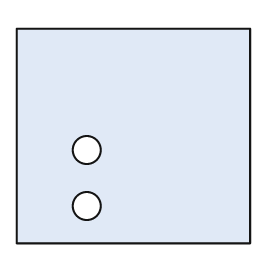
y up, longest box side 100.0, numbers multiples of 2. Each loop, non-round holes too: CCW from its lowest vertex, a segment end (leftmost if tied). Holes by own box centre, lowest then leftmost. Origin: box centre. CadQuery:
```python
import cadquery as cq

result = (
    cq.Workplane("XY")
    .moveTo(-50.0, -46.0)
    .lineTo(50.0, -46.0)
    .lineTo(50.0, 46.0)
    .lineTo(-50.0, 46.0)
    .close()
    .moveTo(-20.0, -30.0)
    .circle(6.0)
    .moveTo(-20.0, -6.0)
    .circle(6.0)
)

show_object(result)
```